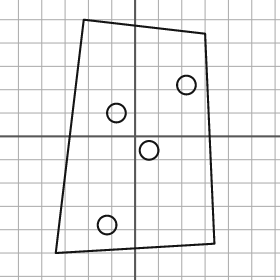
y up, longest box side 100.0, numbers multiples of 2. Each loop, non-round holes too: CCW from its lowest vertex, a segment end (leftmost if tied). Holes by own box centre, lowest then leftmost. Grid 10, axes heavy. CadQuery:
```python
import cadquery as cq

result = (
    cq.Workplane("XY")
    .moveTo(-34.0, -50.0)
    .lineTo(34.0, -46.0)
    .lineTo(30.0, 44.0)
    .lineTo(-22.0, 50.0)
    .close()
    .moveTo(-12.0, -38.0)
    .circle(4.0)
    .moveTo(6.0, -6.0)
    .circle(4.0)
    .moveTo(-8.0, 10.0)
    .circle(4.0)
    .moveTo(22.0, 22.0)
    .circle(4.0)
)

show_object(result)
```